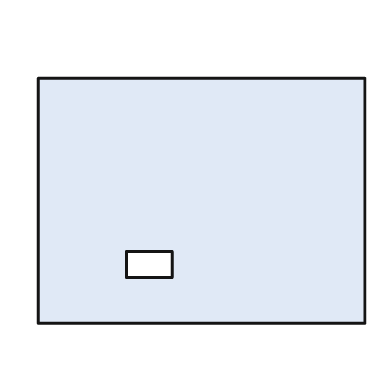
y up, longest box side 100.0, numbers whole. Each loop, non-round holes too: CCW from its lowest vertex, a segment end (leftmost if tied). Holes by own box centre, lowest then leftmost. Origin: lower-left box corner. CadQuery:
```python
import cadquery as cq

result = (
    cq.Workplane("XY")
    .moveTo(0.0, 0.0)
    .lineTo(100.0, 0.0)
    .lineTo(100.0, 75.0)
    .lineTo(0.0, 75.0)
    .close()
    .moveTo(27.0, 14.0)
    .lineTo(41.0, 14.0)
    .lineTo(41.0, 22.0)
    .lineTo(27.0, 22.0)
    .close()
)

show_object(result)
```